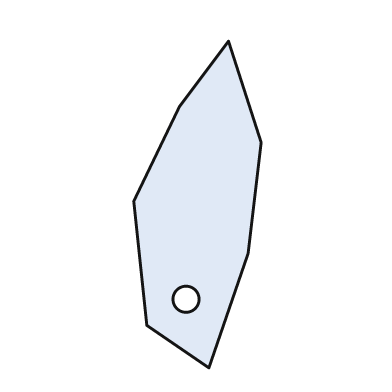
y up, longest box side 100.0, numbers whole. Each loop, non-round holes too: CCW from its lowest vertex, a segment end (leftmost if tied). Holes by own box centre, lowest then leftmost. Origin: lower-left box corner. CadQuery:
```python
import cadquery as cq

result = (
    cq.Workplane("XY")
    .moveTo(23.0, 0.0)
    .lineTo(35.0, 35.0)
    .lineTo(39.0, 69.0)
    .lineTo(29.0, 100.0)
    .lineTo(14.0, 80.0)
    .lineTo(0.0, 51.0)
    .lineTo(4.0, 13.0)
    .close()
    .moveTo(16.0, 21.0)
    .circle(4.0)
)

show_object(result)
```